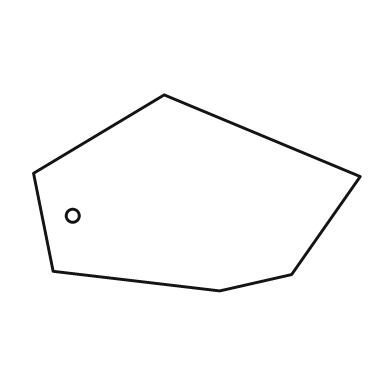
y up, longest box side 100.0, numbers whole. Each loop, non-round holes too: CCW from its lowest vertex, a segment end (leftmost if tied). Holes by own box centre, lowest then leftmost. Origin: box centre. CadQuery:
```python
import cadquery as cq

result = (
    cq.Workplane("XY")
    .moveTo(7.0, -30.0)
    .lineTo(29.0, -25.0)
    .lineTo(50.0, 5.0)
    .lineTo(-10.0, 30.0)
    .lineTo(-50.0, 6.0)
    .lineTo(-44.0, -24.0)
    .close()
    .moveTo(-38.0, -7.0)
    .circle(2.0)
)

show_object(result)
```